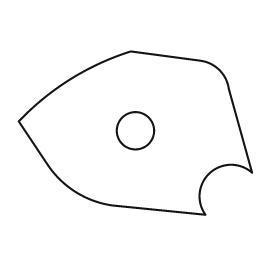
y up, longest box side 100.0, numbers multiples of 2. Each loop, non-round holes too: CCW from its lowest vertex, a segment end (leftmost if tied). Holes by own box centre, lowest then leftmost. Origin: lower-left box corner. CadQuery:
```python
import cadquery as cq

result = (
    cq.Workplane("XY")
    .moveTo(80.0, 0.0)
    .threePointArc((82.0, 18.0), (100.0, 18.0))
    .lineTo(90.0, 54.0)
    .threePointArc((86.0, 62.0), (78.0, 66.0))
    .lineTo(48.0, 70.0)
    .threePointArc((22.0, 58.0), (0.0, 40.0))
    .lineTo(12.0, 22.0)
    .threePointArc((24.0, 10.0), (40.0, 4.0))
    .close()
    .moveTo(50.0, 36.0)
    .circle(8.0)
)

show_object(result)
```